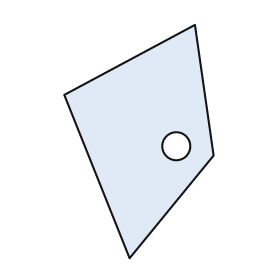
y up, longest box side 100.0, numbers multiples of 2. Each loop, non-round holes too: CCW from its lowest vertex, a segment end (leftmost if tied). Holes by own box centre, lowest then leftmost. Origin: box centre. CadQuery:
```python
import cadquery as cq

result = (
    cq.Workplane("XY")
    .moveTo(-4.0, -50.0)
    .lineTo(32.0, -6.0)
    .lineTo(24.0, 50.0)
    .lineTo(-32.0, 20.0)
    .close()
    .moveTo(16.0, -2.0)
    .circle(6.0)
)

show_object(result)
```